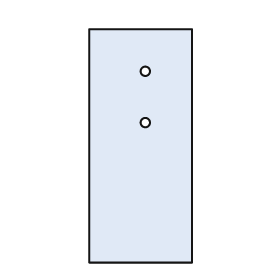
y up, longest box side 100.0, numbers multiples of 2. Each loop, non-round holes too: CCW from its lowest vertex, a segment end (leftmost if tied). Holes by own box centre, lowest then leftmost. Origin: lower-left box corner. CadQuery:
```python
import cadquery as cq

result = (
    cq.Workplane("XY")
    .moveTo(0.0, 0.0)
    .lineTo(44.0, 0.0)
    .lineTo(44.0, 100.0)
    .lineTo(0.0, 100.0)
    .close()
    .moveTo(24.0, 60.0)
    .circle(2.0)
    .moveTo(24.0, 82.0)
    .circle(2.0)
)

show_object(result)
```